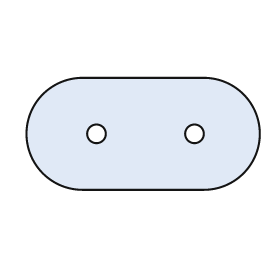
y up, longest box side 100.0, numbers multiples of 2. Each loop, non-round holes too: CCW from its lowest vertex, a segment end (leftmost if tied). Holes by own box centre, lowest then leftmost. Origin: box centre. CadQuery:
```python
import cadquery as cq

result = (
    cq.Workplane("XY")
    .moveTo(-26.0, -24.0)
    .lineTo(26.0, -24.0)
    .threePointArc((50.0, 0.0), (26.0, 24.0))
    .lineTo(-26.0, 24.0)
    .threePointArc((-50.0, 0.0), (-26.0, -24.0))
    .close()
    .moveTo(-20.0, 0.0)
    .circle(4.0)
    .moveTo(22.0, 0.0)
    .circle(4.0)
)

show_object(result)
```